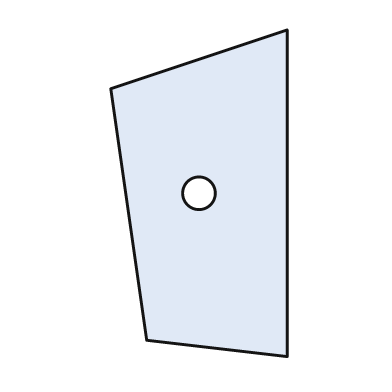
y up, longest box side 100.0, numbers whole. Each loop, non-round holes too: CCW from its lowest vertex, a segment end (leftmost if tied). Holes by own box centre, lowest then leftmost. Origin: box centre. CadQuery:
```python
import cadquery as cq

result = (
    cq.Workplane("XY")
    .moveTo(27.0, -50.0)
    .lineTo(27.0, 50.0)
    .lineTo(-27.0, 32.0)
    .lineTo(-16.0, -45.0)
    .close()
    .moveTo(0.0, 0.0)
    .circle(5.0)
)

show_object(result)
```